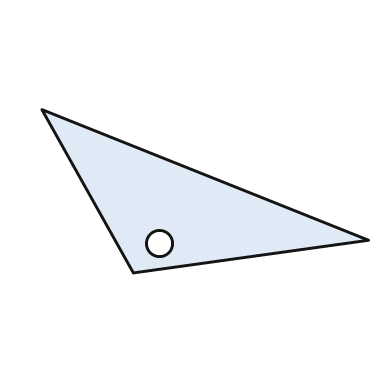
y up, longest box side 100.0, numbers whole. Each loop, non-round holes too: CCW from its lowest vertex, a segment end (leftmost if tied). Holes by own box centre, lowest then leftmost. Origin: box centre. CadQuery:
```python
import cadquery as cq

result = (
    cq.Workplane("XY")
    .moveTo(-22.0, -25.0)
    .lineTo(50.0, -15.0)
    .lineTo(-50.0, 25.0)
    .close()
    .moveTo(-14.0, -16.0)
    .circle(4.0)
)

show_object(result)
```